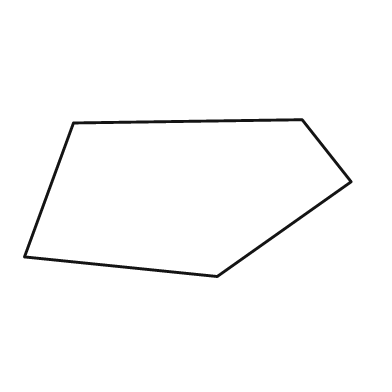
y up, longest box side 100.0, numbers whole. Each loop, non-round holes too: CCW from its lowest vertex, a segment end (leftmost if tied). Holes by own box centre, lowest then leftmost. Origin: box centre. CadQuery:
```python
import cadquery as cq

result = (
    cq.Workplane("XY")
    .moveTo(9.0, -24.0)
    .lineTo(50.0, 5.0)
    .lineTo(35.0, 24.0)
    .lineTo(-35.0, 23.0)
    .lineTo(-50.0, -18.0)
    .close()
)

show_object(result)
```